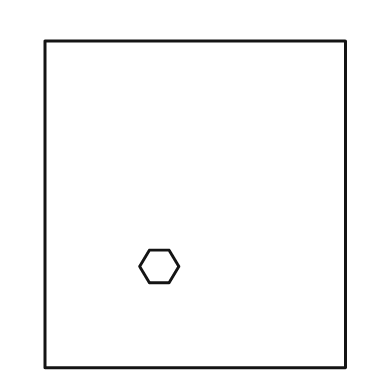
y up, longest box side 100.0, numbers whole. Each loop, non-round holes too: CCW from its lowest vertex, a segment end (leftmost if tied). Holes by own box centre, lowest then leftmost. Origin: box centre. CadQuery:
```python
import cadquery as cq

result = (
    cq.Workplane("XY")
    .moveTo(-46.0, -50.0)
    .lineTo(46.0, -50.0)
    .lineTo(46.0, 50.0)
    .lineTo(-46.0, 50.0)
    .close()
    .moveTo(-14.0, -24.0)
    .lineTo(-8.0, -24.0)
    .lineTo(-5.0, -19.0)
    .lineTo(-8.0, -14.0)
    .lineTo(-14.0, -14.0)
    .lineTo(-17.0, -19.0)
    .close()
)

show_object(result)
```